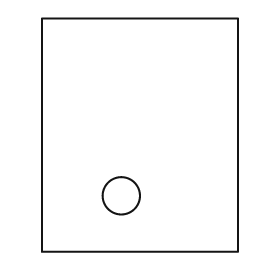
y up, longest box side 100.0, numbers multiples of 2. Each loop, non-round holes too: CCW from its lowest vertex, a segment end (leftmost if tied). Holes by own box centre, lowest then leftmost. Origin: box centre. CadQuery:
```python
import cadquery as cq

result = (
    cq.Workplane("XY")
    .moveTo(-42.0, -50.0)
    .lineTo(42.0, -50.0)
    .lineTo(42.0, 50.0)
    .lineTo(-42.0, 50.0)
    .close()
    .moveTo(-8.0, -26.0)
    .circle(8.0)
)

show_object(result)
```